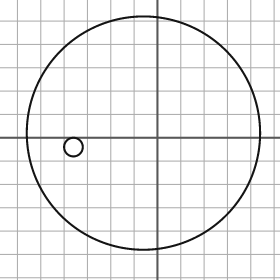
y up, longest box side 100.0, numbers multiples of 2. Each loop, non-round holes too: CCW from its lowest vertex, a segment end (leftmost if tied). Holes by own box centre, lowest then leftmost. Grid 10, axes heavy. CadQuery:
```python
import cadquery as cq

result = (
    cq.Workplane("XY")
    .moveTo(-6.0, 2.0)
    .circle(50.0)
    .moveTo(-36.0, -4.0)
    .circle(4.0)
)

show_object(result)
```